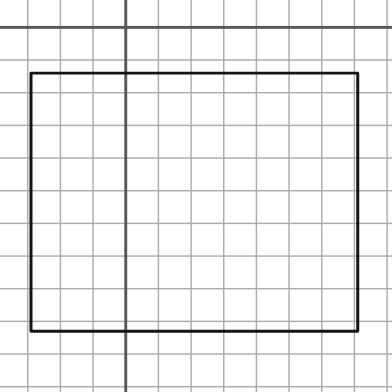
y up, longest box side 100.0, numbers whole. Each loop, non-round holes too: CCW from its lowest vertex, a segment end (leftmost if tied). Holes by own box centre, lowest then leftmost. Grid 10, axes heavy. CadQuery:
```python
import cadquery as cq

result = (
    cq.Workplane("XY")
    .moveTo(-29.0, -93.0)
    .lineTo(71.0, -93.0)
    .lineTo(71.0, -14.0)
    .lineTo(-29.0, -14.0)
    .close()
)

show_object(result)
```